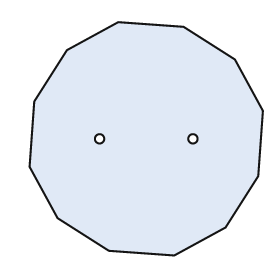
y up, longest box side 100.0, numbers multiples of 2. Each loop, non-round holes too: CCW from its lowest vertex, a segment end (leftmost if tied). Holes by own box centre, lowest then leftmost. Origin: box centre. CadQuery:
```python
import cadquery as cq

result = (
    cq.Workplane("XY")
    .moveTo(12.0, -50.0)
    .lineTo(34.0, -38.0)
    .lineTo(48.0, -16.0)
    .lineTo(50.0, 12.0)
    .lineTo(38.0, 34.0)
    .lineTo(16.0, 48.0)
    .lineTo(-12.0, 50.0)
    .lineTo(-34.0, 38.0)
    .lineTo(-48.0, 16.0)
    .lineTo(-50.0, -12.0)
    .lineTo(-38.0, -34.0)
    .lineTo(-16.0, -48.0)
    .close()
    .moveTo(-20.0, 0.0)
    .circle(2.0)
    .moveTo(20.0, 0.0)
    .circle(2.0)
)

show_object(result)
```